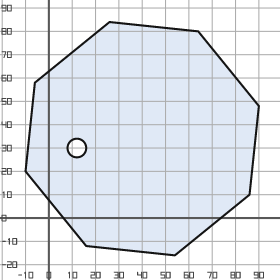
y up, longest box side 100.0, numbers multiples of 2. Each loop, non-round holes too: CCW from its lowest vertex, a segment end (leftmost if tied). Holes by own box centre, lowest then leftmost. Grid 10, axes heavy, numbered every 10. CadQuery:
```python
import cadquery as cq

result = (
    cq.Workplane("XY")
    .moveTo(54.0, -16.0)
    .lineTo(86.0, 10.0)
    .lineTo(90.0, 48.0)
    .lineTo(64.0, 80.0)
    .lineTo(26.0, 84.0)
    .lineTo(-6.0, 58.0)
    .lineTo(-10.0, 20.0)
    .lineTo(16.0, -12.0)
    .close()
    .moveTo(12.0, 30.0)
    .circle(4.0)
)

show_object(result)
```